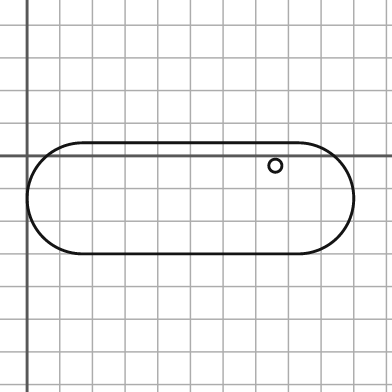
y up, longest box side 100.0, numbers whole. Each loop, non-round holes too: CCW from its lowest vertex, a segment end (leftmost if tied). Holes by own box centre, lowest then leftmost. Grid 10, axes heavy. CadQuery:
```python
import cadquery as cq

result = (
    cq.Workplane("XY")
    .moveTo(17.0, -30.0)
    .lineTo(83.0, -30.0)
    .threePointArc((100.0, -13.0), (83.0, 4.0))
    .lineTo(17.0, 4.0)
    .threePointArc((0.0, -13.0), (17.0, -30.0))
    .close()
    .moveTo(76.0, -3.0)
    .circle(2.0)
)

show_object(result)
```